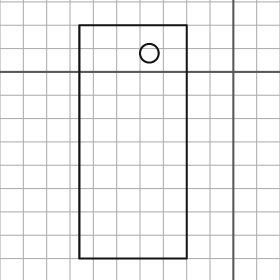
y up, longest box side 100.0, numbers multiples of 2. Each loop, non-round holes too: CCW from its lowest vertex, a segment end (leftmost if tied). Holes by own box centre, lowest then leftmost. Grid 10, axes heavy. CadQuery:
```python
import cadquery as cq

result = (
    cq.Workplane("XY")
    .moveTo(-66.0, -80.0)
    .lineTo(-20.0, -80.0)
    .lineTo(-20.0, 20.0)
    .lineTo(-66.0, 20.0)
    .close()
    .moveTo(-36.0, 8.0)
    .circle(4.0)
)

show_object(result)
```